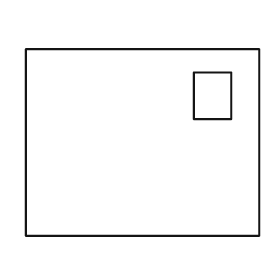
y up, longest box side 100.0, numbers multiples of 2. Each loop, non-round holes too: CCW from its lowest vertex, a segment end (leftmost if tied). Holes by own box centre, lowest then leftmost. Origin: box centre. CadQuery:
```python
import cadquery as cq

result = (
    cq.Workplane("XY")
    .moveTo(-50.0, -40.0)
    .lineTo(50.0, -40.0)
    .lineTo(50.0, 40.0)
    .lineTo(-50.0, 40.0)
    .close()
    .moveTo(22.0, 10.0)
    .lineTo(38.0, 10.0)
    .lineTo(38.0, 30.0)
    .lineTo(22.0, 30.0)
    .close()
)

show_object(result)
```